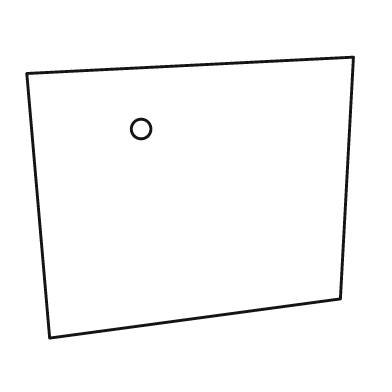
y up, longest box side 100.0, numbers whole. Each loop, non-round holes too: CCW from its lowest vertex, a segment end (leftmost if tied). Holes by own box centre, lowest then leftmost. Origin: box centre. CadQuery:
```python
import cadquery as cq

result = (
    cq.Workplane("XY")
    .moveTo(-43.0, -43.0)
    .lineTo(46.0, -31.0)
    .lineTo(50.0, 43.0)
    .lineTo(-50.0, 38.0)
    .close()
    .moveTo(-15.0, 21.0)
    .circle(3.0)
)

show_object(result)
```